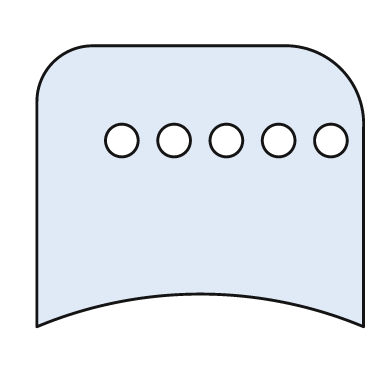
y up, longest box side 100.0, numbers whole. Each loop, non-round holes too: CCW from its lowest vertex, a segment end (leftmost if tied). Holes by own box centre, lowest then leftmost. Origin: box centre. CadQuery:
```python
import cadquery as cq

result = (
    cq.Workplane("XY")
    .moveTo(-50.0, -43.0)
    .threePointArc((0.0, -33.0), (50.0, -43.0))
    .lineTo(50.0, 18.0)
    .threePointArc((43.0, 36.0), (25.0, 43.0))
    .lineTo(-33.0, 43.0)
    .threePointArc((-45.0, 38.0), (-50.0, 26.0))
    .close()
    .moveTo(-24.0, 14.0)
    .circle(5.0)
    .moveTo(-8.0, 14.0)
    .circle(5.0)
    .moveTo(8.0, 14.0)
    .circle(5.0)
    .moveTo(24.0, 14.0)
    .circle(5.0)
    .moveTo(40.0, 14.0)
    .circle(5.0)
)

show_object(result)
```